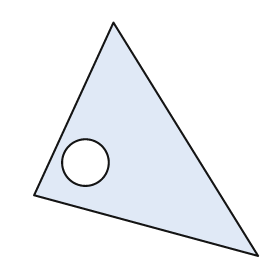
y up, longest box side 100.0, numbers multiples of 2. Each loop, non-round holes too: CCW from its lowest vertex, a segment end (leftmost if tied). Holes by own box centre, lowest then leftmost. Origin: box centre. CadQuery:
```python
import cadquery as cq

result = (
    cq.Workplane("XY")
    .moveTo(48.0, -50.0)
    .lineTo(-14.0, 50.0)
    .lineTo(-48.0, -24.0)
    .close()
    .moveTo(-26.0, -10.0)
    .circle(10.0)
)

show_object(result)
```